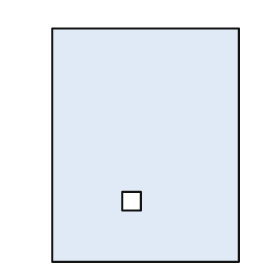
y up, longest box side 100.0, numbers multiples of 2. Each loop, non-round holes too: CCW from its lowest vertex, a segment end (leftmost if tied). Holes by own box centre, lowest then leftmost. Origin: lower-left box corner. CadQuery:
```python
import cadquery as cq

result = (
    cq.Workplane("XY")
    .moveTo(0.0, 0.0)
    .lineTo(80.0, 0.0)
    .lineTo(80.0, 100.0)
    .lineTo(0.0, 100.0)
    .close()
    .moveTo(30.0, 22.0)
    .lineTo(38.0, 22.0)
    .lineTo(38.0, 30.0)
    .lineTo(30.0, 30.0)
    .close()
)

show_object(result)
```